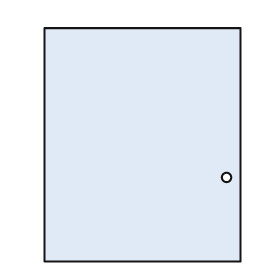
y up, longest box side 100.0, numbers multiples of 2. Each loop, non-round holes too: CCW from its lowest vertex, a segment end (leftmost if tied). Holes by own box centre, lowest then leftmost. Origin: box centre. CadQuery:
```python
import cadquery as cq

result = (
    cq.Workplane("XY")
    .moveTo(-42.0, -50.0)
    .lineTo(42.0, -50.0)
    .lineTo(42.0, 50.0)
    .lineTo(-42.0, 50.0)
    .close()
    .moveTo(36.0, -14.0)
    .circle(2.0)
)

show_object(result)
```